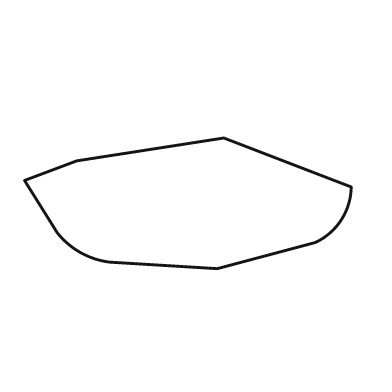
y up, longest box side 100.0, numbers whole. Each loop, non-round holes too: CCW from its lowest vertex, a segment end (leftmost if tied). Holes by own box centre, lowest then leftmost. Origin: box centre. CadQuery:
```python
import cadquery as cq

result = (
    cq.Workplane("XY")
    .moveTo(9.0, -20.0)
    .lineTo(39.0, -12.0)
    .threePointArc((47.0, -5.0), (50.0, 5.0))
    .lineTo(11.0, 20.0)
    .lineTo(-34.0, 13.0)
    .lineTo(-50.0, 7.0)
    .lineTo(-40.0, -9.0)
    .threePointArc((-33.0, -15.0), (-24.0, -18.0))
    .close()
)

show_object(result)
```